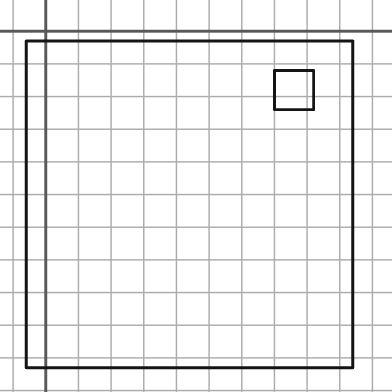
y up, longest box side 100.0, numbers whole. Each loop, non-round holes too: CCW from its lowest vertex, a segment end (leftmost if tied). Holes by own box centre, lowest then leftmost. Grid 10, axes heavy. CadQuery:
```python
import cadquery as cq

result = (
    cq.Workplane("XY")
    .moveTo(-6.0, -103.0)
    .lineTo(94.0, -103.0)
    .lineTo(94.0, -3.0)
    .lineTo(-6.0, -3.0)
    .close()
    .moveTo(70.0, -24.0)
    .lineTo(82.0, -24.0)
    .lineTo(82.0, -12.0)
    .lineTo(70.0, -12.0)
    .close()
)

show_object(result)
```